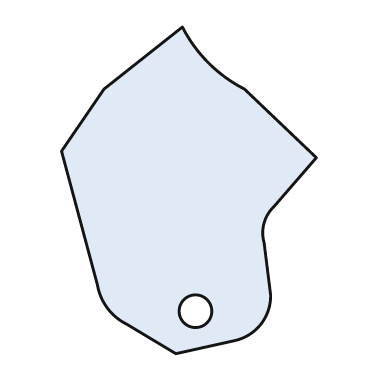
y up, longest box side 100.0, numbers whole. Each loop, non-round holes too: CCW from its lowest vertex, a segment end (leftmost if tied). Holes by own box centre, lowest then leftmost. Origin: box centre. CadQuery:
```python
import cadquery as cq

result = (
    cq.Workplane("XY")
    .moveTo(-4.0, -50.0)
    .lineTo(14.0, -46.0)
    .threePointArc((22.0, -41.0), (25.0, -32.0))
    .lineTo(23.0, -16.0)
    .threePointArc((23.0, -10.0), (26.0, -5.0))
    .lineTo(39.0, 10.0)
    .lineTo(17.0, 31.0)
    .threePointArc((6.0, 39.0), (-2.0, 50.0))
    .lineTo(-26.0, 31.0)
    .lineTo(-39.0, 12.0)
    .lineTo(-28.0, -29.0)
    .threePointArc((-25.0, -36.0), (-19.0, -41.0))
    .close()
    .moveTo(2.0, -37.0)
    .circle(5.0)
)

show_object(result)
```